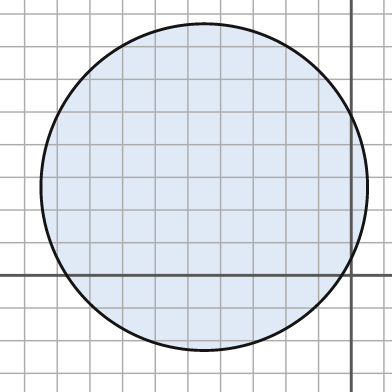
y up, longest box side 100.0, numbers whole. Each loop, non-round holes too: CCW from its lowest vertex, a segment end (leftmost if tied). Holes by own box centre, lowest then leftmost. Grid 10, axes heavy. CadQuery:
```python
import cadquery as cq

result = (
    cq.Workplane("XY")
    .moveTo(-45.0, 27.0)
    .circle(50.0)
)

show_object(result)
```